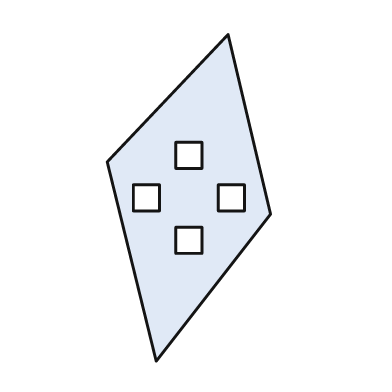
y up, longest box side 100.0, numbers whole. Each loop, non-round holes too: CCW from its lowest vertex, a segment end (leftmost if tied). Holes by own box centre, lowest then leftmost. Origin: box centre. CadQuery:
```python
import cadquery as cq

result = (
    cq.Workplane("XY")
    .moveTo(-10.0, -50.0)
    .lineTo(25.0, -5.0)
    .lineTo(12.0, 50.0)
    .lineTo(-25.0, 11.0)
    .close()
    .moveTo(-4.0, -17.0)
    .lineTo(4.0, -17.0)
    .lineTo(4.0, -9.0)
    .lineTo(-4.0, -9.0)
    .close()
    .moveTo(-17.0, -4.0)
    .lineTo(-9.0, -4.0)
    .lineTo(-9.0, 4.0)
    .lineTo(-17.0, 4.0)
    .close()
    .moveTo(9.0, -4.0)
    .lineTo(17.0, -4.0)
    .lineTo(17.0, 4.0)
    .lineTo(9.0, 4.0)
    .close()
    .moveTo(-4.0, 9.0)
    .lineTo(4.0, 9.0)
    .lineTo(4.0, 17.0)
    .lineTo(-4.0, 17.0)
    .close()
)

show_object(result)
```